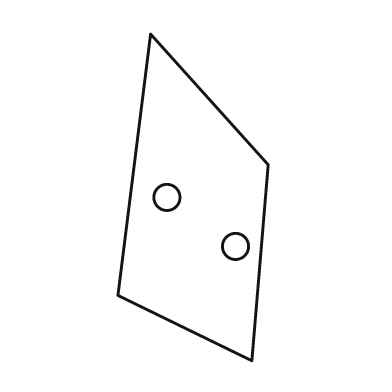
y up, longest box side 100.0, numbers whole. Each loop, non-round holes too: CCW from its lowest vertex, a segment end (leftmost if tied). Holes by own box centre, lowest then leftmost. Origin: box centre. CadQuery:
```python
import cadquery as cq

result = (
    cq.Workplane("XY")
    .moveTo(18.0, -50.0)
    .lineTo(23.0, 10.0)
    .lineTo(-13.0, 50.0)
    .lineTo(-23.0, -30.0)
    .close()
    .moveTo(13.0, -15.0)
    .circle(4.0)
    .moveTo(-8.0, 0.0)
    .circle(4.0)
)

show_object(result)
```